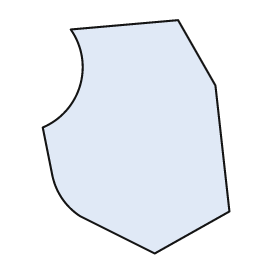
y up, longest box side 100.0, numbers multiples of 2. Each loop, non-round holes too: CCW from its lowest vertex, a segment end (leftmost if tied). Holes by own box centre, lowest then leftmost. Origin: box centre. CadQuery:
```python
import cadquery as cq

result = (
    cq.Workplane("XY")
    .moveTo(8.0, -50.0)
    .lineTo(40.0, -32.0)
    .lineTo(34.0, 22.0)
    .lineTo(18.0, 50.0)
    .lineTo(-28.0, 46.0)
    .threePointArc((-24.0, 22.0), (-40.0, 4.0))
    .lineTo(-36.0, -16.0)
    .threePointArc((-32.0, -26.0), (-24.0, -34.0))
    .close()
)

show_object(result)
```